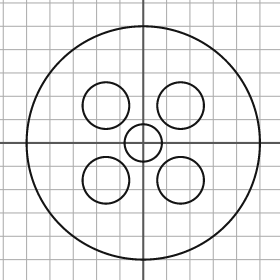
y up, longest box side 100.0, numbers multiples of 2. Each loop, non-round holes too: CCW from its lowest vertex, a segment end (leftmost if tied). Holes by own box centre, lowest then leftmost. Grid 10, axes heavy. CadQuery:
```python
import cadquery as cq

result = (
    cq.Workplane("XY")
    .moveTo(0.0, 0.0)
    .circle(50.0)
    .moveTo(-16.0, -16.0)
    .circle(10.0)
    .moveTo(16.0, -16.0)
    .circle(10.0)
    .moveTo(0.0, 0.0)
    .circle(8.0)
    .moveTo(-16.0, 16.0)
    .circle(10.0)
    .moveTo(16.0, 16.0)
    .circle(10.0)
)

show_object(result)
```